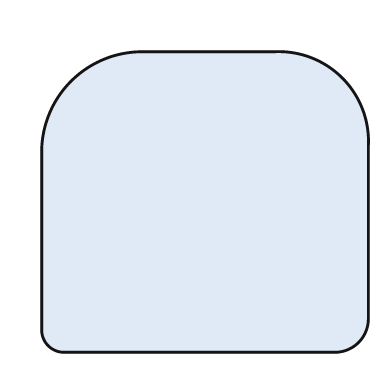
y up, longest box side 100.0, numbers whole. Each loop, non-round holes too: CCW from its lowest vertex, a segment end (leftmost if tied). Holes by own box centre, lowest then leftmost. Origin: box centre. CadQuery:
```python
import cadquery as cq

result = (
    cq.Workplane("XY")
    .moveTo(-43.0, -46.0)
    .lineTo(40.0, -46.0)
    .threePointArc((47.0, -43.0), (50.0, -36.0))
    .lineTo(50.0, 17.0)
    .threePointArc((42.0, 38.0), (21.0, 46.0))
    .lineTo(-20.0, 46.0)
    .threePointArc((-41.0, 37.0), (-50.0, 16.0))
    .lineTo(-50.0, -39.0)
    .threePointArc((-48.0, -44.0), (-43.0, -46.0))
    .close()
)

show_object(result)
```